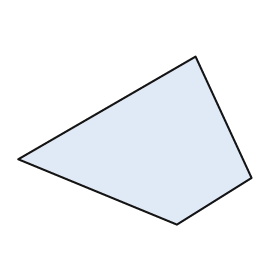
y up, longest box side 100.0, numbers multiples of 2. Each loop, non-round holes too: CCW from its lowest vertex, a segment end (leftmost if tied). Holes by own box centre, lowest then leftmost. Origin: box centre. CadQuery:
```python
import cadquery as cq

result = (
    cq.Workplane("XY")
    .moveTo(18.0, -36.0)
    .lineTo(50.0, -16.0)
    .lineTo(26.0, 36.0)
    .lineTo(-50.0, -8.0)
    .close()
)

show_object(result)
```